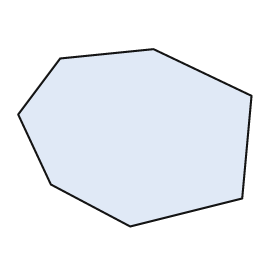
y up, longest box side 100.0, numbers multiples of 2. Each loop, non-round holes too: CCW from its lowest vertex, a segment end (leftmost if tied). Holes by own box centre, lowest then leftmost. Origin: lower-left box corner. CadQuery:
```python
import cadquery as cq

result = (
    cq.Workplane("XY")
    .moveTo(48.0, 0.0)
    .lineTo(96.0, 12.0)
    .lineTo(100.0, 56.0)
    .lineTo(58.0, 76.0)
    .lineTo(18.0, 72.0)
    .lineTo(0.0, 48.0)
    .lineTo(14.0, 18.0)
    .close()
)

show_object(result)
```